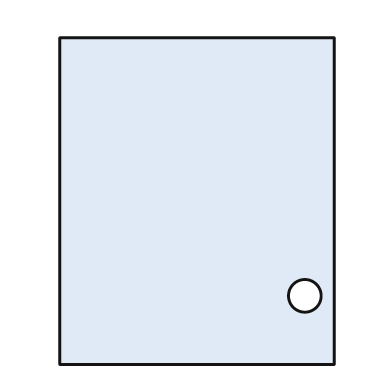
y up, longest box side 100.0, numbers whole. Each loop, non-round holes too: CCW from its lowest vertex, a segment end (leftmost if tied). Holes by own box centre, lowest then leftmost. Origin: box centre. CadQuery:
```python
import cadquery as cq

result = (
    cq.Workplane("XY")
    .moveTo(-42.0, -50.0)
    .lineTo(42.0, -50.0)
    .lineTo(42.0, 50.0)
    .lineTo(-42.0, 50.0)
    .close()
    .moveTo(33.0, -29.0)
    .circle(5.0)
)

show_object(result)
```